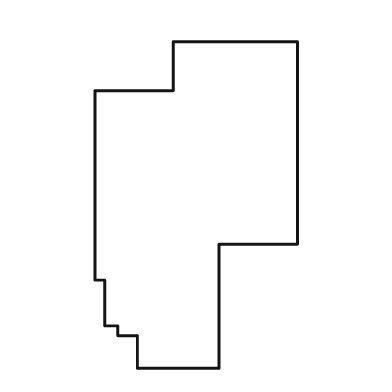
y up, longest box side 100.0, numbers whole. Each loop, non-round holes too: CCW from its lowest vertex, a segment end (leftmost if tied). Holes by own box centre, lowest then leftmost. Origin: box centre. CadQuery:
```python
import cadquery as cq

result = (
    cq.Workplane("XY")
    .moveTo(-18.0, -50.0)
    .lineTo(7.0, -50.0)
    .lineTo(7.0, -12.0)
    .lineTo(31.0, -12.0)
    .lineTo(31.0, 50.0)
    .lineTo(-7.0, 50.0)
    .lineTo(-7.0, 35.0)
    .lineTo(-31.0, 35.0)
    .lineTo(-31.0, -23.0)
    .lineTo(-28.0, -23.0)
    .lineTo(-28.0, -37.0)
    .lineTo(-24.0, -37.0)
    .lineTo(-24.0, -40.0)
    .lineTo(-18.0, -40.0)
    .close()
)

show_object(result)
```